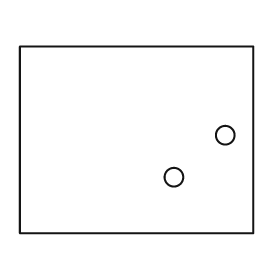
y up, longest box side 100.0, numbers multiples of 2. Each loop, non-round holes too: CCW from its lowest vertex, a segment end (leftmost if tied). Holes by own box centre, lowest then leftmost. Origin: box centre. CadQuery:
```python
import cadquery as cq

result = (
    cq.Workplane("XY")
    .moveTo(-50.0, -40.0)
    .lineTo(50.0, -40.0)
    .lineTo(50.0, 40.0)
    .lineTo(-50.0, 40.0)
    .close()
    .moveTo(16.0, -16.0)
    .circle(4.0)
    .moveTo(38.0, 2.0)
    .circle(4.0)
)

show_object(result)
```